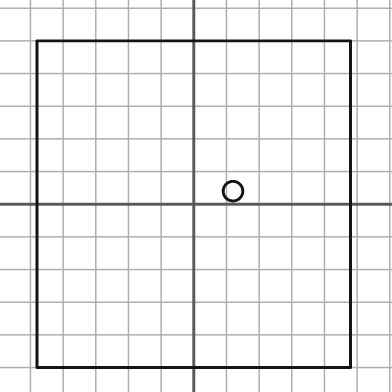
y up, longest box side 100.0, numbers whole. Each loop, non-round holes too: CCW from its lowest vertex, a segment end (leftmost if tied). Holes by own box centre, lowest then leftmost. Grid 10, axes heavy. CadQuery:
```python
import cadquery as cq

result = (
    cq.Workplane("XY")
    .moveTo(-48.0, -50.0)
    .lineTo(48.0, -50.0)
    .lineTo(48.0, 50.0)
    .lineTo(-48.0, 50.0)
    .close()
    .moveTo(12.0, 4.0)
    .circle(3.0)
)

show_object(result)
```